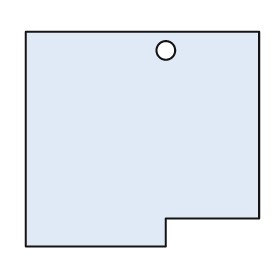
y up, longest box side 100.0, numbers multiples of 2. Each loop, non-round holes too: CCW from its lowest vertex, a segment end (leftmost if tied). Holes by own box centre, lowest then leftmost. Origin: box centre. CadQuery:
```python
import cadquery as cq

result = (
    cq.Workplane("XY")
    .moveTo(-50.0, -46.0)
    .lineTo(10.0, -46.0)
    .lineTo(10.0, -34.0)
    .lineTo(50.0, -34.0)
    .lineTo(50.0, 46.0)
    .lineTo(-50.0, 46.0)
    .close()
    .moveTo(10.0, 38.0)
    .circle(4.0)
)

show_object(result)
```